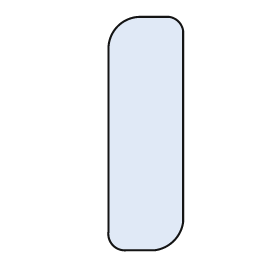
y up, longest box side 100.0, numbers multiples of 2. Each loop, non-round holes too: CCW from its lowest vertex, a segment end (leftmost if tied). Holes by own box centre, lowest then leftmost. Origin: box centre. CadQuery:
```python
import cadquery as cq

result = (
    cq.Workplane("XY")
    .moveTo(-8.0, -50.0)
    .lineTo(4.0, -50.0)
    .threePointArc((12.0, -46.0), (16.0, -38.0))
    .lineTo(16.0, 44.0)
    .threePointArc((14.0, 48.0), (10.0, 50.0))
    .lineTo(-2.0, 50.0)
    .threePointArc((-12.0, 46.0), (-16.0, 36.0))
    .lineTo(-16.0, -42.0)
    .threePointArc((-14.0, -48.0), (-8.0, -50.0))
    .close()
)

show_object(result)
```